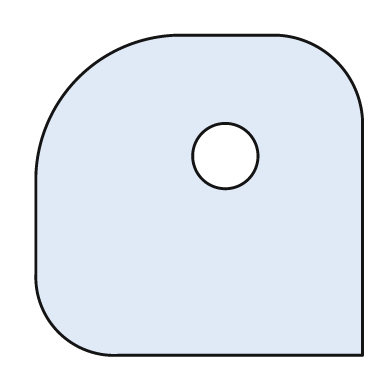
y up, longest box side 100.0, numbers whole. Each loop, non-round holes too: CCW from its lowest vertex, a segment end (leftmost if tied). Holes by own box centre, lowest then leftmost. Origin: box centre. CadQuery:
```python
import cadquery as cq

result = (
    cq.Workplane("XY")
    .moveTo(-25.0, -49.0)
    .lineTo(50.0, -49.0)
    .lineTo(50.0, 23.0)
    .threePointArc((42.0, 41.0), (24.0, 49.0))
    .lineTo(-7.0, 49.0)
    .threePointArc((-37.0, 36.0), (-50.0, 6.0))
    .lineTo(-50.0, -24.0)
    .threePointArc((-43.0, -42.0), (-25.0, -49.0))
    .close()
    .moveTo(8.0, 12.0)
    .circle(10.0)
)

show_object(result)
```